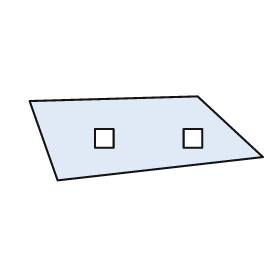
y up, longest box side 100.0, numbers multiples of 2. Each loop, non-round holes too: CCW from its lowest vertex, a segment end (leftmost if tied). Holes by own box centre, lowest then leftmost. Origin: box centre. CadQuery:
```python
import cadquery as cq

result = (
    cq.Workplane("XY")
    .moveTo(-38.0, -18.0)
    .lineTo(50.0, -8.0)
    .lineTo(22.0, 18.0)
    .lineTo(-50.0, 16.0)
    .close()
    .moveTo(-22.0, -4.0)
    .lineTo(-14.0, -4.0)
    .lineTo(-14.0, 4.0)
    .lineTo(-22.0, 4.0)
    .close()
    .moveTo(16.0, -4.0)
    .lineTo(24.0, -4.0)
    .lineTo(24.0, 4.0)
    .lineTo(16.0, 4.0)
    .close()
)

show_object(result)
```